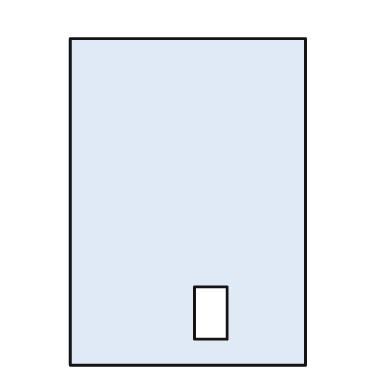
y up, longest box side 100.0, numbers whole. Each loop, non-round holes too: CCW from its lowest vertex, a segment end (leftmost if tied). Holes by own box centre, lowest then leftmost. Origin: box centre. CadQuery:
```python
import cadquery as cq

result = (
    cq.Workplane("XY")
    .moveTo(-36.0, -50.0)
    .lineTo(36.0, -50.0)
    .lineTo(36.0, 50.0)
    .lineTo(-36.0, 50.0)
    .close()
    .moveTo(2.0, -42.0)
    .lineTo(12.0, -42.0)
    .lineTo(12.0, -26.0)
    .lineTo(2.0, -26.0)
    .close()
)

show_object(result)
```